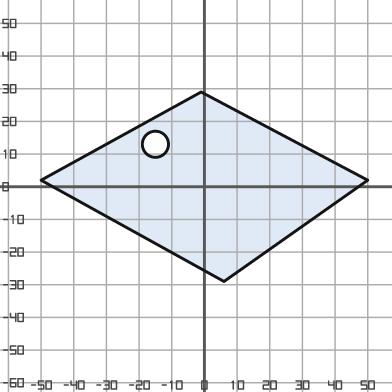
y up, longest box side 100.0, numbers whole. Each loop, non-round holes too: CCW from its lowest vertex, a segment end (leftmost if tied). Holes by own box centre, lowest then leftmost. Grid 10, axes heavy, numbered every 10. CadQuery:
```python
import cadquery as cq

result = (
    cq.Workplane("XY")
    .moveTo(6.0, -29.0)
    .lineTo(50.0, 2.0)
    .lineTo(-1.0, 29.0)
    .lineTo(-50.0, 2.0)
    .close()
    .moveTo(-15.0, 13.0)
    .circle(4.0)
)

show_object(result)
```